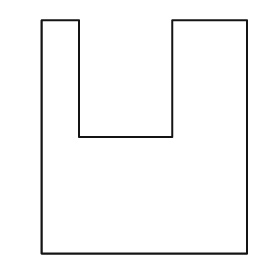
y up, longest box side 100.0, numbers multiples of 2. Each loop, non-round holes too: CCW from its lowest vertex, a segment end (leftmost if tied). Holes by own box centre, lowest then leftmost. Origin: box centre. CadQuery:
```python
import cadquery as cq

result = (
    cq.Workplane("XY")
    .moveTo(-44.0, -50.0)
    .lineTo(44.0, -50.0)
    .lineTo(44.0, 50.0)
    .lineTo(12.0, 50.0)
    .lineTo(12.0, 0.0)
    .lineTo(-28.0, 0.0)
    .lineTo(-28.0, 50.0)
    .lineTo(-44.0, 50.0)
    .close()
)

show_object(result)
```